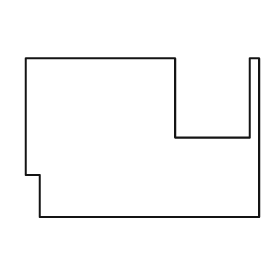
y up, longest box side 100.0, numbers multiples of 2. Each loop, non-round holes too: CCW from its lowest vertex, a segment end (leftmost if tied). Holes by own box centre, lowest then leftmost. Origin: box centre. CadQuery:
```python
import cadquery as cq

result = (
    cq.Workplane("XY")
    .moveTo(-44.0, -34.0)
    .lineTo(50.0, -34.0)
    .lineTo(50.0, 34.0)
    .lineTo(46.0, 34.0)
    .lineTo(46.0, 0.0)
    .lineTo(14.0, 0.0)
    .lineTo(14.0, 34.0)
    .lineTo(-50.0, 34.0)
    .lineTo(-50.0, -16.0)
    .lineTo(-44.0, -16.0)
    .close()
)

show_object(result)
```